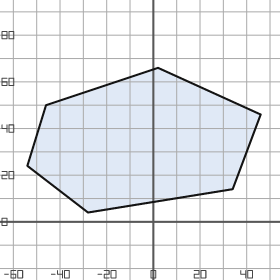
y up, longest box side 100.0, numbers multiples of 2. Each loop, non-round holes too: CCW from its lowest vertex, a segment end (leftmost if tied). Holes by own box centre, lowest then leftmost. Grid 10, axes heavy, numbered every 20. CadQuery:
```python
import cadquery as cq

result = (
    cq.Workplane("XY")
    .moveTo(-28.0, 4.0)
    .lineTo(34.0, 14.0)
    .lineTo(46.0, 46.0)
    .lineTo(2.0, 66.0)
    .lineTo(-46.0, 50.0)
    .lineTo(-54.0, 24.0)
    .close()
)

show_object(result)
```